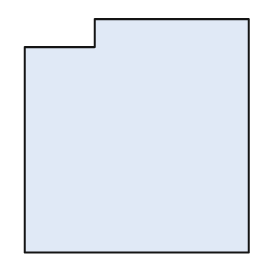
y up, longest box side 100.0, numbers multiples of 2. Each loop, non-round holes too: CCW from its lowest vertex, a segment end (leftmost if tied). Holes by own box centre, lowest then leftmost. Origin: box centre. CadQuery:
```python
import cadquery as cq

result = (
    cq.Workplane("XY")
    .moveTo(-48.0, -50.0)
    .lineTo(48.0, -50.0)
    .lineTo(48.0, 50.0)
    .lineTo(-18.0, 50.0)
    .lineTo(-18.0, 38.0)
    .lineTo(-48.0, 38.0)
    .close()
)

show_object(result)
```